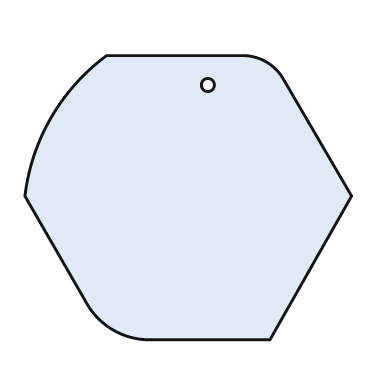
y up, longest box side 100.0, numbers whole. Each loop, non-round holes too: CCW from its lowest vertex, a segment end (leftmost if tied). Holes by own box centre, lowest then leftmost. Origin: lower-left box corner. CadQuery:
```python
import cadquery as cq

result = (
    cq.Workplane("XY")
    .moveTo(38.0, 0.0)
    .lineTo(75.0, 0.0)
    .lineTo(100.0, 44.0)
    .lineTo(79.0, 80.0)
    .threePointArc((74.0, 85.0), (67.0, 87.0))
    .lineTo(25.0, 87.0)
    .threePointArc((8.0, 68.0), (0.0, 44.0))
    .lineTo(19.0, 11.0)
    .threePointArc((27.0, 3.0), (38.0, 0.0))
    .close()
    .moveTo(56.0, 78.0)
    .circle(2.0)
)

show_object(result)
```